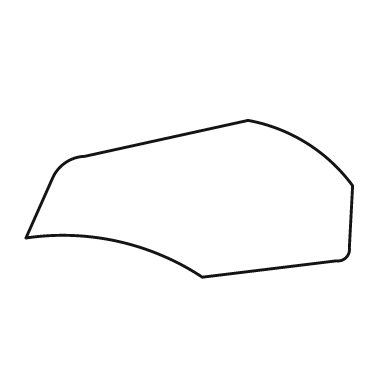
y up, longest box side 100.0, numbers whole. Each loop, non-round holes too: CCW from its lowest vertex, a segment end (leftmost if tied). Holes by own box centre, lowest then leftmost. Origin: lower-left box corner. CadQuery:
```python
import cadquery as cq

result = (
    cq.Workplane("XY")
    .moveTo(54.0, 0.0)
    .lineTo(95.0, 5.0)
    .threePointArc((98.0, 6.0), (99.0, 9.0))
    .lineTo(100.0, 28.0)
    .threePointArc((86.0, 41.0), (68.0, 48.0))
    .lineTo(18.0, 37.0)
    .threePointArc((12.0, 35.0), (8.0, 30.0))
    .lineTo(0.0, 12.0)
    .threePointArc((28.0, 11.0), (54.0, 0.0))
    .close()
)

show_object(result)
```